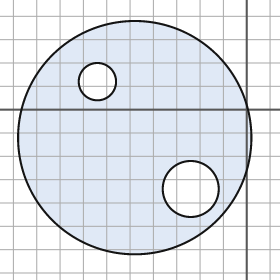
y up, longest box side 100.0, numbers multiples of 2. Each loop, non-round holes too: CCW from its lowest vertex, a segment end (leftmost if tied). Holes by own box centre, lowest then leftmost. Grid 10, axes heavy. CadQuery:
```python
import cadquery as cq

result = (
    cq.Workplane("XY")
    .moveTo(-48.0, -12.0)
    .circle(50.0)
    .moveTo(-24.0, -34.0)
    .circle(12.0)
    .moveTo(-64.0, 12.0)
    .circle(8.0)
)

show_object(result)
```